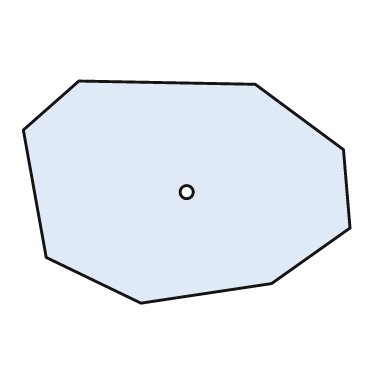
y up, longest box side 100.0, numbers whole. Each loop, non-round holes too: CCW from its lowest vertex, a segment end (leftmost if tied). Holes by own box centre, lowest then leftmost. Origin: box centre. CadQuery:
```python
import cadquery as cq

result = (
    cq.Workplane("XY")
    .moveTo(-14.0, -34.0)
    .lineTo(26.0, -28.0)
    .lineTo(50.0, -11.0)
    .lineTo(48.0, 13.0)
    .lineTo(21.0, 33.0)
    .lineTo(-33.0, 34.0)
    .lineTo(-50.0, 19.0)
    .lineTo(-43.0, -20.0)
    .close()
    .moveTo(0.0, 0.0)
    .circle(2.0)
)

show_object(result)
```